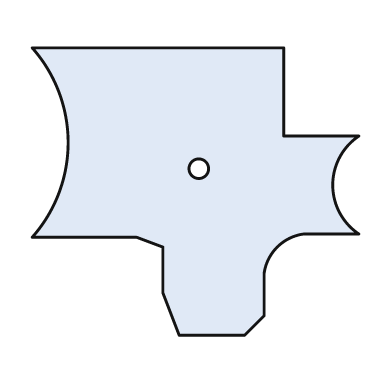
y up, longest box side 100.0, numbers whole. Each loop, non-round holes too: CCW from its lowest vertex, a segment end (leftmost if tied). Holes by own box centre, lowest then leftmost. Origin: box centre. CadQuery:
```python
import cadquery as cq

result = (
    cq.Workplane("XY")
    .moveTo(-5.0, -44.0)
    .lineTo(15.0, -44.0)
    .lineTo(21.0, -38.0)
    .lineTo(21.0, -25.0)
    .threePointArc((25.0, -17.0), (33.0, -13.0))
    .lineTo(50.0, -13.0)
    .threePointArc((42.0, 2.0), (50.0, 17.0))
    .lineTo(27.0, 17.0)
    .lineTo(27.0, 44.0)
    .lineTo(-50.0, 44.0)
    .threePointArc((-39.0, 15.0), (-50.0, -14.0))
    .lineTo(-18.0, -14.0)
    .lineTo(-10.0, -17.0)
    .lineTo(-10.0, -31.0)
    .close()
    .moveTo(1.0, 7.0)
    .circle(3.0)
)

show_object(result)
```